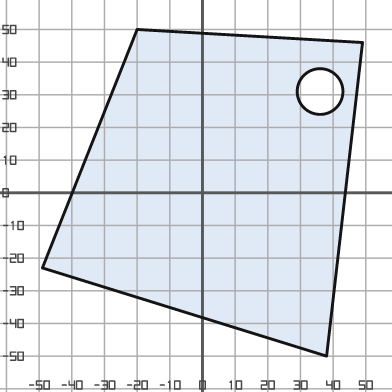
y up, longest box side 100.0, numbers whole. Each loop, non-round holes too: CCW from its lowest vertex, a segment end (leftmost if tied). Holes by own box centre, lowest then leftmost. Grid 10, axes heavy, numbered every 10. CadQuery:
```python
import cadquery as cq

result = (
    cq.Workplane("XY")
    .moveTo(38.0, -50.0)
    .lineTo(49.0, 46.0)
    .lineTo(-20.0, 50.0)
    .lineTo(-49.0, -23.0)
    .close()
    .moveTo(36.0, 31.0)
    .circle(7.0)
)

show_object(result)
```